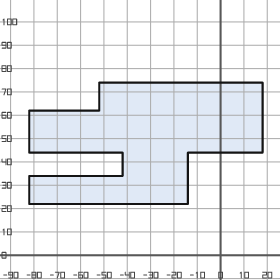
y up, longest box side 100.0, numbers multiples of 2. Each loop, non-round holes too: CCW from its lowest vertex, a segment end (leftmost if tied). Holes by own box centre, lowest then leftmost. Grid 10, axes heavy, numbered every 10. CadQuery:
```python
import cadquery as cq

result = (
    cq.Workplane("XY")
    .moveTo(-82.0, 22.0)
    .lineTo(-14.0, 22.0)
    .lineTo(-14.0, 44.0)
    .lineTo(18.0, 44.0)
    .lineTo(18.0, 74.0)
    .lineTo(-52.0, 74.0)
    .lineTo(-52.0, 62.0)
    .lineTo(-82.0, 62.0)
    .lineTo(-82.0, 44.0)
    .lineTo(-42.0, 44.0)
    .lineTo(-42.0, 34.0)
    .lineTo(-82.0, 34.0)
    .close()
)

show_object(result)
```